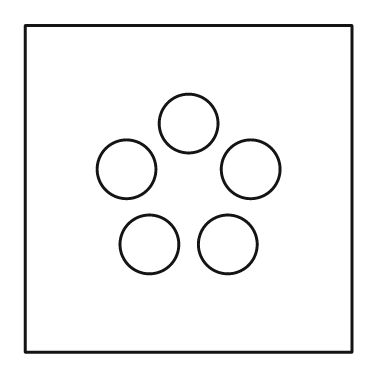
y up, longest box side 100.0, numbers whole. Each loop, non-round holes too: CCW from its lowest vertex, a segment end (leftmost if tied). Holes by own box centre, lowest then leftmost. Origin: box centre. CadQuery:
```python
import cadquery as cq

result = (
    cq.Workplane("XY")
    .moveTo(-50.0, -50.0)
    .lineTo(50.0, -50.0)
    .lineTo(50.0, 50.0)
    .lineTo(-50.0, 50.0)
    .close()
    .moveTo(-12.0, -17.0)
    .circle(9.0)
    .moveTo(12.0, -17.0)
    .circle(9.0)
    .moveTo(-19.0, 6.0)
    .circle(9.0)
    .moveTo(19.0, 6.0)
    .circle(9.0)
    .moveTo(0.0, 20.0)
    .circle(9.0)
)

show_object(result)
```